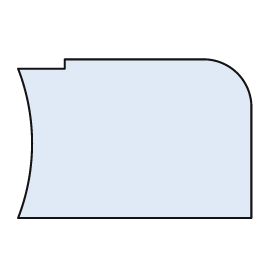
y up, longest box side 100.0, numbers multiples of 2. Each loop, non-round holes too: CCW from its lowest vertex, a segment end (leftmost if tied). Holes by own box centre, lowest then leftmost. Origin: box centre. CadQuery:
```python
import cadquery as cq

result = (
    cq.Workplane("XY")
    .moveTo(-50.0, -34.0)
    .lineTo(50.0, -34.0)
    .lineTo(50.0, 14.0)
    .threePointArc((44.0, 28.0), (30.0, 34.0))
    .lineTo(-30.0, 34.0)
    .lineTo(-30.0, 30.0)
    .lineTo(-50.0, 30.0)
    .threePointArc((-44.0, -2.0), (-50.0, -34.0))
    .close()
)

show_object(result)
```